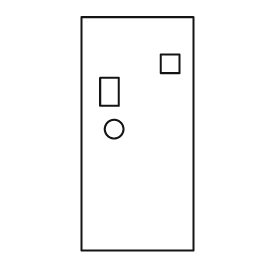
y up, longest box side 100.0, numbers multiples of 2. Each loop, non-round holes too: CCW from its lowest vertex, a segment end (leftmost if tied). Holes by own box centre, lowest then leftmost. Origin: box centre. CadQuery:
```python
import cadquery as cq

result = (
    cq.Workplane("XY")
    .moveTo(-24.0, -50.0)
    .lineTo(24.0, -50.0)
    .lineTo(24.0, 50.0)
    .lineTo(-24.0, 50.0)
    .close()
    .moveTo(-10.0, 2.0)
    .circle(4.0)
    .moveTo(-16.0, 12.0)
    .lineTo(-8.0, 12.0)
    .lineTo(-8.0, 24.0)
    .lineTo(-16.0, 24.0)
    .close()
    .moveTo(10.0, 26.0)
    .lineTo(18.0, 26.0)
    .lineTo(18.0, 34.0)
    .lineTo(10.0, 34.0)
    .close()
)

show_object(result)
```